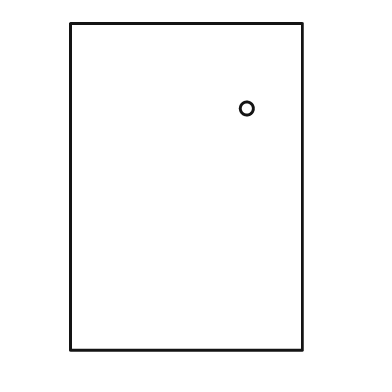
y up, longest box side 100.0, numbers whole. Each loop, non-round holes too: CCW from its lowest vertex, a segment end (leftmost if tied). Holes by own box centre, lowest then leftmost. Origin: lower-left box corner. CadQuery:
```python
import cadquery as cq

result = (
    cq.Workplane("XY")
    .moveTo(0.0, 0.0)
    .lineTo(71.0, 0.0)
    .lineTo(71.0, 100.0)
    .lineTo(0.0, 100.0)
    .close()
    .moveTo(54.0, 74.0)
    .circle(2.0)
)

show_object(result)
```